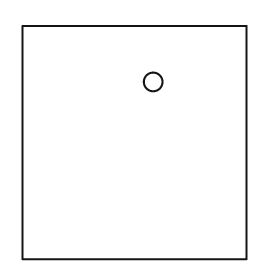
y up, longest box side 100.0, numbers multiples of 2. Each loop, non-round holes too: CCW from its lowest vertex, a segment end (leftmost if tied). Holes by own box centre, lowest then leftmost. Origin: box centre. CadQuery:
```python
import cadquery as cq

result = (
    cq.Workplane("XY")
    .moveTo(-48.0, -50.0)
    .lineTo(48.0, -50.0)
    .lineTo(48.0, 50.0)
    .lineTo(-48.0, 50.0)
    .close()
    .moveTo(8.0, 26.0)
    .circle(4.0)
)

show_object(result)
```